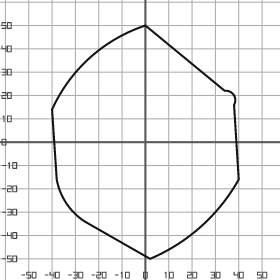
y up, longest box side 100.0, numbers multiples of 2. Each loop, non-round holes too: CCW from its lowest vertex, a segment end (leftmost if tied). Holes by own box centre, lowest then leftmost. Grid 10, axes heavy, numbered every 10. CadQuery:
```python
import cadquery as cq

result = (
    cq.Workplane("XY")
    .moveTo(2.0, -50.0)
    .threePointArc((24.0, -36.0), (40.0, -16.0))
    .lineTo(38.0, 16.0)
    .threePointArc((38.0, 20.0), (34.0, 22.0))
    .lineTo(0.0, 50.0)
    .threePointArc((-24.0, 36.0), (-40.0, 14.0))
    .lineTo(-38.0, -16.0)
    .threePointArc((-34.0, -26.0), (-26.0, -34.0))
    .close()
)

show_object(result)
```